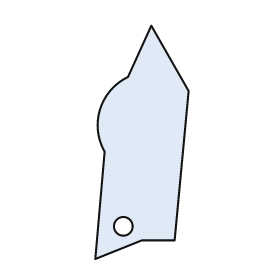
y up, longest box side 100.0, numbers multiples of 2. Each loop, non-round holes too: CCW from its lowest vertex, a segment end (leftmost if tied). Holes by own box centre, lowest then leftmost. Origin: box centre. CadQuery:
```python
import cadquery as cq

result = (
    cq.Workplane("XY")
    .moveTo(-20.0, -50.0)
    .lineTo(0.0, -42.0)
    .lineTo(14.0, -42.0)
    .lineTo(20.0, 22.0)
    .lineTo(4.0, 50.0)
    .lineTo(-6.0, 28.0)
    .threePointArc((-18.0, 14.0), (-16.0, -4.0))
    .close()
    .moveTo(-8.0, -36.0)
    .circle(4.0)
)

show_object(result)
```